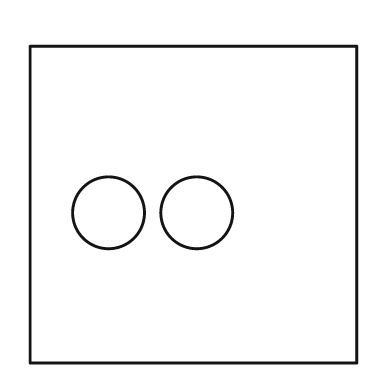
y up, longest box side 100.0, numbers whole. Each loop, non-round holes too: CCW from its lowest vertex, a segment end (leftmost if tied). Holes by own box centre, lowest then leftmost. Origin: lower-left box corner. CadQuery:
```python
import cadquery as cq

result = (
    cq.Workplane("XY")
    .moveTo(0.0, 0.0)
    .lineTo(100.0, 0.0)
    .lineTo(100.0, 97.0)
    .lineTo(0.0, 97.0)
    .close()
    .moveTo(24.0, 46.0)
    .circle(11.0)
    .moveTo(51.0, 46.0)
    .circle(11.0)
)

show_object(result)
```